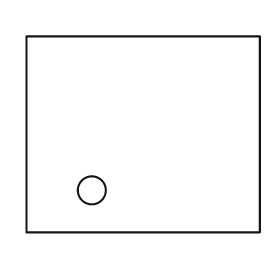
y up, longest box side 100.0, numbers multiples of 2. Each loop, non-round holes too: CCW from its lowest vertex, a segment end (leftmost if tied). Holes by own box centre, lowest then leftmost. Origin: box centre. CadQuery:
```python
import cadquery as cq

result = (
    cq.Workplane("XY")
    .moveTo(-50.0, -42.0)
    .lineTo(50.0, -42.0)
    .lineTo(50.0, 42.0)
    .lineTo(-50.0, 42.0)
    .close()
    .moveTo(-22.0, -24.0)
    .circle(6.0)
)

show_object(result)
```